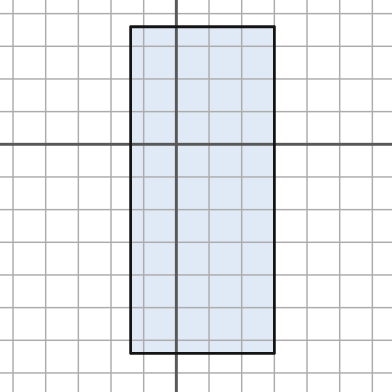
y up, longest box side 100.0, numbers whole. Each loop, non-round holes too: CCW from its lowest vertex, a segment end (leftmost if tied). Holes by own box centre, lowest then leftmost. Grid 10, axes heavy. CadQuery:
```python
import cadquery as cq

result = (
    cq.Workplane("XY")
    .moveTo(-14.0, -64.0)
    .lineTo(30.0, -64.0)
    .lineTo(30.0, 36.0)
    .lineTo(-14.0, 36.0)
    .close()
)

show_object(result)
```